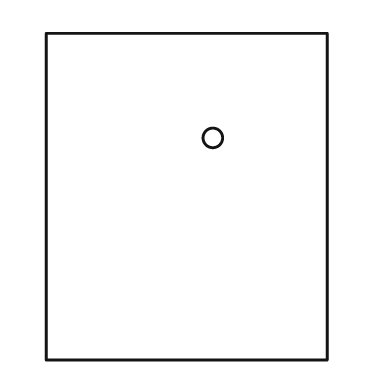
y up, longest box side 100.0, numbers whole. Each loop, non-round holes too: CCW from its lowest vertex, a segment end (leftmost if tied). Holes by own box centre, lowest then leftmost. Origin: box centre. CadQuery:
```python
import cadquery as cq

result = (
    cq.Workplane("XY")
    .moveTo(-43.0, -50.0)
    .lineTo(43.0, -50.0)
    .lineTo(43.0, 50.0)
    .lineTo(-43.0, 50.0)
    .close()
    .moveTo(8.0, 18.0)
    .circle(3.0)
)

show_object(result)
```